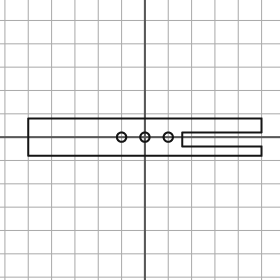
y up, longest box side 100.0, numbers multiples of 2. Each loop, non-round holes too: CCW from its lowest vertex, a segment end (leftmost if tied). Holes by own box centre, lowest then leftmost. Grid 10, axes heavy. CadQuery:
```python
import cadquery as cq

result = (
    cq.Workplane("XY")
    .moveTo(-50.0, -8.0)
    .lineTo(50.0, -8.0)
    .lineTo(50.0, -4.0)
    .lineTo(16.0, -4.0)
    .lineTo(16.0, 2.0)
    .lineTo(50.0, 2.0)
    .lineTo(50.0, 8.0)
    .lineTo(-50.0, 8.0)
    .close()
    .moveTo(-10.0, 0.0)
    .circle(2.0)
    .moveTo(0.0, 0.0)
    .circle(2.0)
    .moveTo(10.0, 0.0)
    .circle(2.0)
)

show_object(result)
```